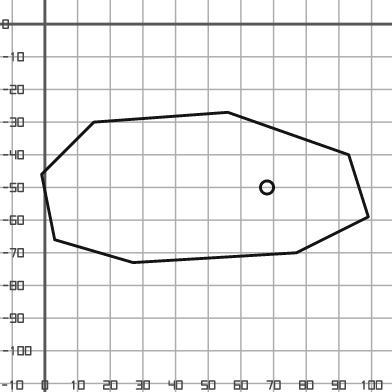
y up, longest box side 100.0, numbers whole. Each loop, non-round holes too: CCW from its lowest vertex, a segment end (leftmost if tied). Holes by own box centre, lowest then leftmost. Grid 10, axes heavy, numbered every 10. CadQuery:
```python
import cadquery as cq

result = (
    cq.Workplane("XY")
    .moveTo(27.0, -73.0)
    .lineTo(77.0, -70.0)
    .lineTo(99.0, -59.0)
    .lineTo(93.0, -40.0)
    .lineTo(56.0, -27.0)
    .lineTo(15.0, -30.0)
    .lineTo(-1.0, -46.0)
    .lineTo(3.0, -66.0)
    .close()
    .moveTo(68.0, -50.0)
    .circle(2.0)
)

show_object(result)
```